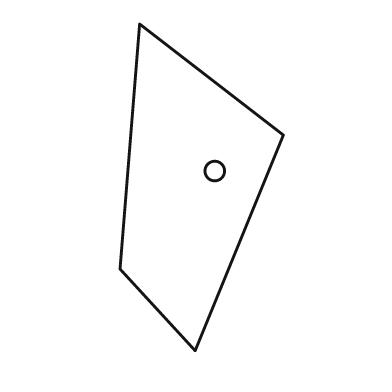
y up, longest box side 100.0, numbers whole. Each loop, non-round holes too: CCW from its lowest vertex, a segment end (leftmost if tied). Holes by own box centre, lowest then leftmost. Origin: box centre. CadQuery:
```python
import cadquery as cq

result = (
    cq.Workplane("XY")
    .moveTo(-2.0, -50.0)
    .lineTo(25.0, 16.0)
    .lineTo(-19.0, 50.0)
    .lineTo(-25.0, -25.0)
    .close()
    .moveTo(4.0, 5.0)
    .circle(3.0)
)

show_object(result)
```